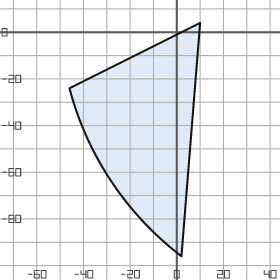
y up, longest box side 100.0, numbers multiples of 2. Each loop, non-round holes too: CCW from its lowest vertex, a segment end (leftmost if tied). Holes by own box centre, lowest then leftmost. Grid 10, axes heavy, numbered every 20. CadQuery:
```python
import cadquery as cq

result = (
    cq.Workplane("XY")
    .moveTo(2.0, -96.0)
    .lineTo(10.0, 4.0)
    .lineTo(-46.0, -24.0)
    .threePointArc((-28.0, -64.0), (2.0, -96.0))
    .close()
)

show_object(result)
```